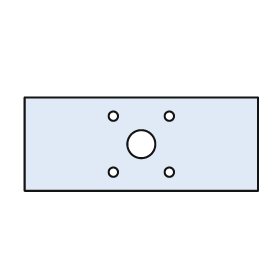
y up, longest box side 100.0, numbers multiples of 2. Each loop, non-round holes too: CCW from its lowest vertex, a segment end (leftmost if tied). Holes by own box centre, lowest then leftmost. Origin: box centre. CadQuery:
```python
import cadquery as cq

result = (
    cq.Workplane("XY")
    .moveTo(-50.0, -20.0)
    .lineTo(50.0, -20.0)
    .lineTo(50.0, 20.0)
    .lineTo(-50.0, 20.0)
    .close()
    .moveTo(-12.0, -12.0)
    .circle(2.0)
    .moveTo(12.0, -12.0)
    .circle(2.0)
    .moveTo(0.0, 0.0)
    .circle(6.0)
    .moveTo(-12.0, 12.0)
    .circle(2.0)
    .moveTo(12.0, 12.0)
    .circle(2.0)
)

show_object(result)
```